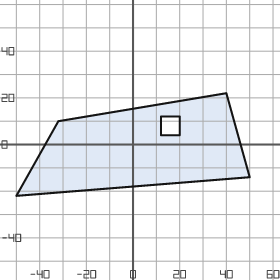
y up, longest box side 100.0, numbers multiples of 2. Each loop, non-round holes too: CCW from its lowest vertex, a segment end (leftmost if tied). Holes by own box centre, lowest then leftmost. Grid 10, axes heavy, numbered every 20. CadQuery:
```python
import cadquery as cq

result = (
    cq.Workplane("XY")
    .moveTo(-50.0, -22.0)
    .lineTo(50.0, -14.0)
    .lineTo(40.0, 22.0)
    .lineTo(-32.0, 10.0)
    .close()
    .moveTo(12.0, 4.0)
    .lineTo(20.0, 4.0)
    .lineTo(20.0, 12.0)
    .lineTo(12.0, 12.0)
    .close()
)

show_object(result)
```